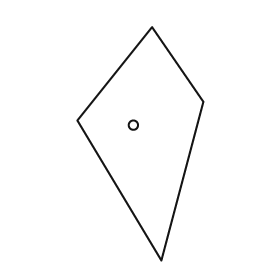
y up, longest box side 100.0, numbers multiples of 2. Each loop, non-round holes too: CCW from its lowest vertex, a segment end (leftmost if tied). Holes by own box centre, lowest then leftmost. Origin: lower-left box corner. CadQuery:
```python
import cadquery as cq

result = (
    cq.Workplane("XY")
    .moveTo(36.0, 0.0)
    .lineTo(54.0, 68.0)
    .lineTo(32.0, 100.0)
    .lineTo(0.0, 60.0)
    .close()
    .moveTo(24.0, 58.0)
    .circle(2.0)
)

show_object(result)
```